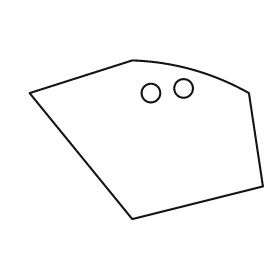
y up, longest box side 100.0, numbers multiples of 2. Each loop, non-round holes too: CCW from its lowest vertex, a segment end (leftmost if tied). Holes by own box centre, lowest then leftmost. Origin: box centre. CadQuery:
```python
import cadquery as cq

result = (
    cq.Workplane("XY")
    .moveTo(-6.0, -34.0)
    .lineTo(50.0, -20.0)
    .lineTo(44.0, 20.0)
    .threePointArc((20.0, 30.0), (-6.0, 34.0))
    .lineTo(-50.0, 20.0)
    .close()
    .moveTo(2.0, 20.0)
    .circle(4.0)
    .moveTo(16.0, 22.0)
    .circle(4.0)
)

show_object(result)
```